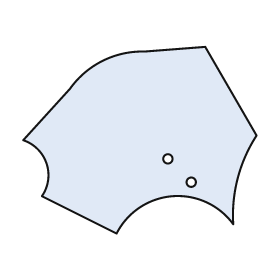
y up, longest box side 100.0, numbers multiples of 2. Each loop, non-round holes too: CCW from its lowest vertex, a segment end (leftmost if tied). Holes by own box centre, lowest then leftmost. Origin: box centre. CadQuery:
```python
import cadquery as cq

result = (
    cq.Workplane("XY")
    .moveTo(-10.0, -40.0)
    .threePointArc((14.0, -24.0), (40.0, -36.0))
    .threePointArc((42.0, -16.0), (50.0, 2.0))
    .lineTo(28.0, 40.0)
    .lineTo(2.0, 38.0)
    .threePointArc((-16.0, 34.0), (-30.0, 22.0))
    .lineTo(-50.0, 0.0)
    .threePointArc((-40.0, -10.0), (-42.0, -24.0))
    .close()
    .moveTo(22.0, -18.0)
    .circle(2.0)
    .moveTo(12.0, -8.0)
    .circle(2.0)
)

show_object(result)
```